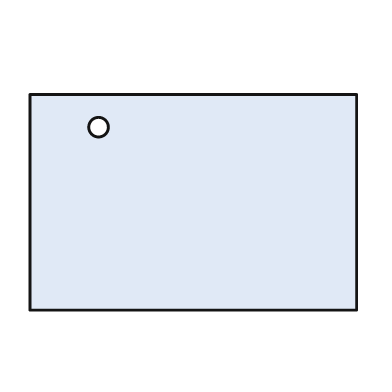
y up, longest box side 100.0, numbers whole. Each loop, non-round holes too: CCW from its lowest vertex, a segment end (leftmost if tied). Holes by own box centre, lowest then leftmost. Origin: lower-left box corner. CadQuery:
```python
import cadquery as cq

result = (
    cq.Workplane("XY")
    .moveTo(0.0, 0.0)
    .lineTo(100.0, 0.0)
    .lineTo(100.0, 66.0)
    .lineTo(0.0, 66.0)
    .close()
    .moveTo(21.0, 56.0)
    .circle(3.0)
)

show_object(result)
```